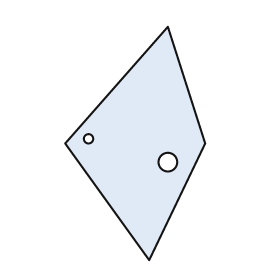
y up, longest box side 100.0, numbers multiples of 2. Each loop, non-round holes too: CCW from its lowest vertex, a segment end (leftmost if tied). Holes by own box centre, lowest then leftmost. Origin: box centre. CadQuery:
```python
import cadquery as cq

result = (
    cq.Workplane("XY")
    .moveTo(6.0, -50.0)
    .lineTo(30.0, 0.0)
    .lineTo(14.0, 50.0)
    .lineTo(-30.0, 0.0)
    .close()
    .moveTo(14.0, -8.0)
    .circle(4.0)
    .moveTo(-20.0, 2.0)
    .circle(2.0)
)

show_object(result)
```